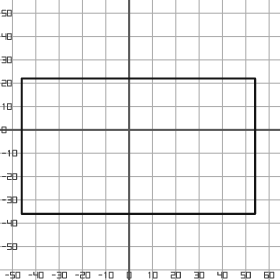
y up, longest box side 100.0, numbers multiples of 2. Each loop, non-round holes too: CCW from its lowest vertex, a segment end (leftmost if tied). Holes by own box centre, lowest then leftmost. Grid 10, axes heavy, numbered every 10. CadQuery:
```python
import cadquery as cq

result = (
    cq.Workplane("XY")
    .moveTo(-46.0, -36.0)
    .lineTo(54.0, -36.0)
    .lineTo(54.0, 22.0)
    .lineTo(-46.0, 22.0)
    .close()
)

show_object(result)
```